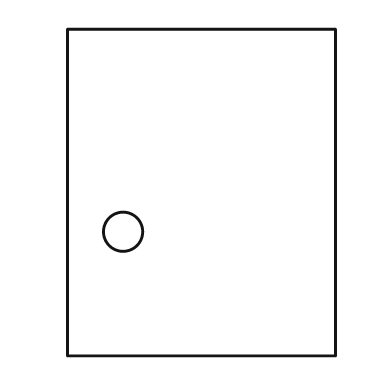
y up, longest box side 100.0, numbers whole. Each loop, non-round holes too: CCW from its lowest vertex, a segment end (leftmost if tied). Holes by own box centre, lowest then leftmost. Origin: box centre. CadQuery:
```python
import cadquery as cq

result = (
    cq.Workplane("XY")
    .moveTo(-41.0, -50.0)
    .lineTo(41.0, -50.0)
    .lineTo(41.0, 50.0)
    .lineTo(-41.0, 50.0)
    .close()
    .moveTo(-24.0, -12.0)
    .circle(6.0)
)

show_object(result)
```